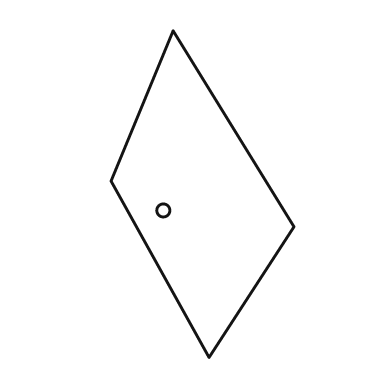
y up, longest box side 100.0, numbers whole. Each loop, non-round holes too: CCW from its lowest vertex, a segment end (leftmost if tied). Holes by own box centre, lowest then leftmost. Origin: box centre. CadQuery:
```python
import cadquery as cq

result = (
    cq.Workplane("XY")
    .moveTo(2.0, -50.0)
    .lineTo(28.0, -10.0)
    .lineTo(-9.0, 50.0)
    .lineTo(-28.0, 4.0)
    .close()
    .moveTo(-12.0, -5.0)
    .circle(2.0)
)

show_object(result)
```